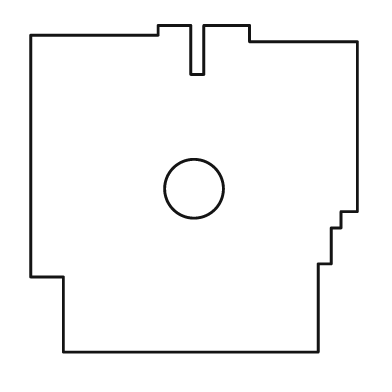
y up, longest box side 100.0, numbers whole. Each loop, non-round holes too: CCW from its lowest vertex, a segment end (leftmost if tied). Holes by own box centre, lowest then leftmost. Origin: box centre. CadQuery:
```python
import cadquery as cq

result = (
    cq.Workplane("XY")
    .moveTo(-40.0, -50.0)
    .lineTo(38.0, -50.0)
    .lineTo(38.0, -23.0)
    .lineTo(42.0, -23.0)
    .lineTo(42.0, -12.0)
    .lineTo(45.0, -12.0)
    .lineTo(45.0, -7.0)
    .lineTo(50.0, -7.0)
    .lineTo(50.0, 45.0)
    .lineTo(17.0, 45.0)
    .lineTo(17.0, 50.0)
    .lineTo(3.0, 50.0)
    .lineTo(3.0, 35.0)
    .lineTo(-1.0, 35.0)
    .lineTo(-1.0, 50.0)
    .lineTo(-11.0, 50.0)
    .lineTo(-11.0, 47.0)
    .lineTo(-50.0, 47.0)
    .lineTo(-50.0, -27.0)
    .lineTo(-40.0, -27.0)
    .close()
    .moveTo(0.0, 0.0)
    .circle(9.0)
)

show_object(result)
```